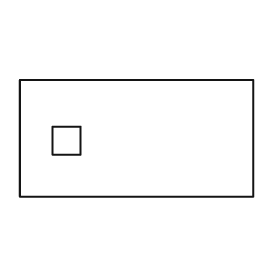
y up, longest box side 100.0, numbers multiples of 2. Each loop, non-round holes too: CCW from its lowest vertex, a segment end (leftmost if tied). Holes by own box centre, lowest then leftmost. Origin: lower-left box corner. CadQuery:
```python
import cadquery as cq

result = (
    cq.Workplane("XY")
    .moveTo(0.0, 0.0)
    .lineTo(100.0, 0.0)
    .lineTo(100.0, 50.0)
    .lineTo(0.0, 50.0)
    .close()
    .moveTo(14.0, 18.0)
    .lineTo(26.0, 18.0)
    .lineTo(26.0, 30.0)
    .lineTo(14.0, 30.0)
    .close()
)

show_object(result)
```